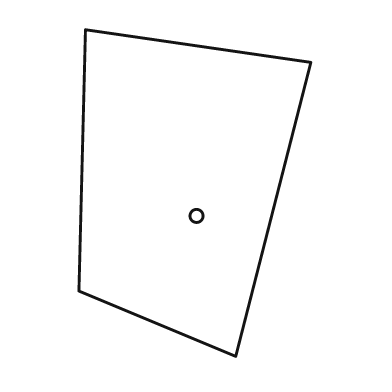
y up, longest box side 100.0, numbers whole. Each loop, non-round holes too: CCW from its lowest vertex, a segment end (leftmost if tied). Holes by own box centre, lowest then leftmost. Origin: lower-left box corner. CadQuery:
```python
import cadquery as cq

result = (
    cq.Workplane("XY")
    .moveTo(48.0, 0.0)
    .lineTo(71.0, 90.0)
    .lineTo(2.0, 100.0)
    .lineTo(0.0, 20.0)
    .close()
    .moveTo(36.0, 43.0)
    .circle(2.0)
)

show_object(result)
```